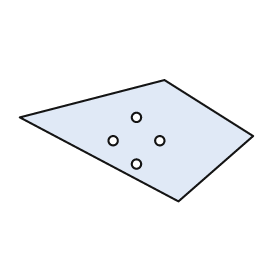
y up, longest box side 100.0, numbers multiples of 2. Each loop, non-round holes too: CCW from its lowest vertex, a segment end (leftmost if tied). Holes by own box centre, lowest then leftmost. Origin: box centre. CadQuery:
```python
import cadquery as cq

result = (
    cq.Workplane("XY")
    .moveTo(18.0, -26.0)
    .lineTo(50.0, 2.0)
    .lineTo(12.0, 26.0)
    .lineTo(-50.0, 10.0)
    .close()
    .moveTo(0.0, -10.0)
    .circle(2.0)
    .moveTo(-10.0, 0.0)
    .circle(2.0)
    .moveTo(10.0, 0.0)
    .circle(2.0)
    .moveTo(0.0, 10.0)
    .circle(2.0)
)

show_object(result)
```